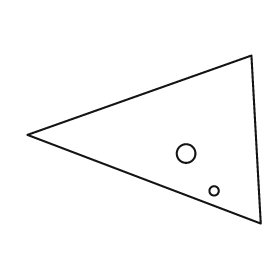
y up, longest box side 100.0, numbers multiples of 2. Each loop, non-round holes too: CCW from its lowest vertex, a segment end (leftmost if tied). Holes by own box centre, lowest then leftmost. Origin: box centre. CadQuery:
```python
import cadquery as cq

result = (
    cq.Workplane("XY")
    .moveTo(50.0, -36.0)
    .lineTo(46.0, 36.0)
    .lineTo(-50.0, 2.0)
    .close()
    .moveTo(30.0, -22.0)
    .circle(2.0)
    .moveTo(18.0, -6.0)
    .circle(4.0)
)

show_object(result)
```